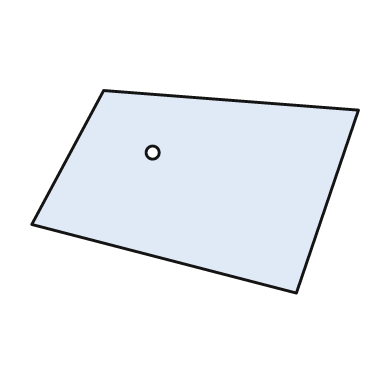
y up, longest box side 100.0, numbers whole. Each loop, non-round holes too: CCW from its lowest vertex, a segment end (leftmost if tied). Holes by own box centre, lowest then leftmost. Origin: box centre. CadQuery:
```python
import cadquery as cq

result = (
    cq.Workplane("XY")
    .moveTo(31.0, -31.0)
    .lineTo(50.0, 25.0)
    .lineTo(-28.0, 31.0)
    .lineTo(-50.0, -10.0)
    .close()
    .moveTo(-13.0, 12.0)
    .circle(2.0)
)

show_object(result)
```